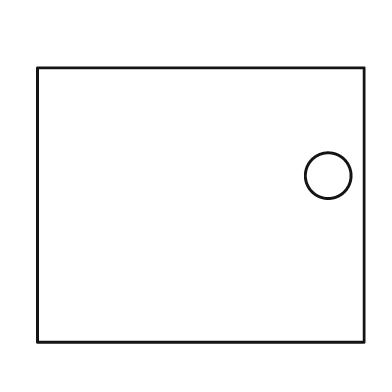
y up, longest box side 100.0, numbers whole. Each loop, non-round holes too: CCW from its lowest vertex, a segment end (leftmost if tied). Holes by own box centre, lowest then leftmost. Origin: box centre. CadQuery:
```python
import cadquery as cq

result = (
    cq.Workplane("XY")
    .moveTo(-50.0, -42.0)
    .lineTo(50.0, -42.0)
    .lineTo(50.0, 42.0)
    .lineTo(-50.0, 42.0)
    .close()
    .moveTo(39.0, 9.0)
    .circle(7.0)
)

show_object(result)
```